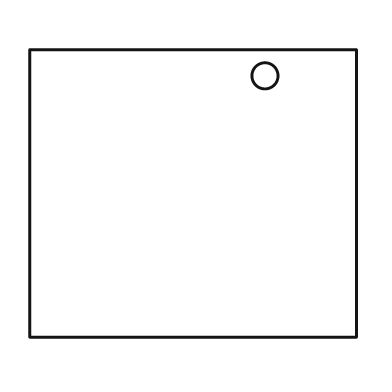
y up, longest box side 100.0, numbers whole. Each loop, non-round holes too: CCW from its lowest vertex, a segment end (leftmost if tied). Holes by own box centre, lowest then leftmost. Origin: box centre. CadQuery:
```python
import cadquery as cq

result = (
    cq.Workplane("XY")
    .moveTo(-50.0, -44.0)
    .lineTo(50.0, -44.0)
    .lineTo(50.0, 44.0)
    .lineTo(-50.0, 44.0)
    .close()
    .moveTo(22.0, 36.0)
    .circle(4.0)
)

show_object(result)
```